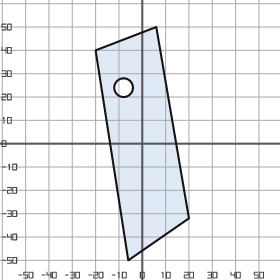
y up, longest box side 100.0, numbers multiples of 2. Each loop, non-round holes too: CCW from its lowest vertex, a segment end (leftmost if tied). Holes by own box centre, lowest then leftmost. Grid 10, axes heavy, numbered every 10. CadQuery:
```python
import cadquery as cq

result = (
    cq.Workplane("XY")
    .moveTo(-6.0, -50.0)
    .lineTo(20.0, -32.0)
    .lineTo(6.0, 50.0)
    .lineTo(-20.0, 40.0)
    .close()
    .moveTo(-8.0, 24.0)
    .circle(4.0)
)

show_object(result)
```